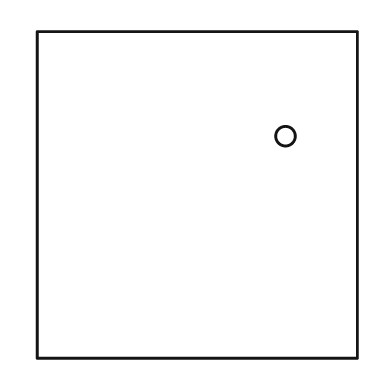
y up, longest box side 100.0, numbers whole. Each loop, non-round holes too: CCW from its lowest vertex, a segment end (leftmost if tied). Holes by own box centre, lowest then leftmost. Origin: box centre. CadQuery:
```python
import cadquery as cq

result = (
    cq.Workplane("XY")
    .moveTo(-49.0, -50.0)
    .lineTo(49.0, -50.0)
    .lineTo(49.0, 50.0)
    .lineTo(-49.0, 50.0)
    .close()
    .moveTo(27.0, 18.0)
    .circle(3.0)
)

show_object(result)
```